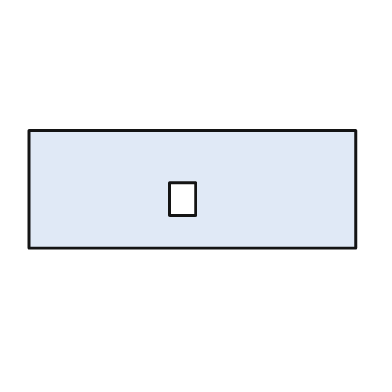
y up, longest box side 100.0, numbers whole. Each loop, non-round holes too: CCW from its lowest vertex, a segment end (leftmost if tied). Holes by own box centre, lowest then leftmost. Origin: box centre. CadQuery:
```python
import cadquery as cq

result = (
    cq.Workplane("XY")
    .moveTo(-50.0, -18.0)
    .lineTo(50.0, -18.0)
    .lineTo(50.0, 18.0)
    .lineTo(-50.0, 18.0)
    .close()
    .moveTo(-7.0, -8.0)
    .lineTo(1.0, -8.0)
    .lineTo(1.0, 2.0)
    .lineTo(-7.0, 2.0)
    .close()
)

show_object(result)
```